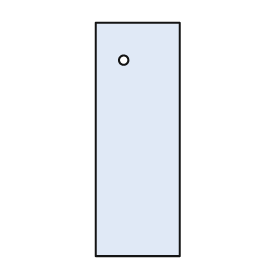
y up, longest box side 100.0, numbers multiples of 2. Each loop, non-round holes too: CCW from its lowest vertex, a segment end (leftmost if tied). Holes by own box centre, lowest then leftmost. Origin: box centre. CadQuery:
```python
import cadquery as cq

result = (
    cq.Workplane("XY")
    .moveTo(-18.0, -50.0)
    .lineTo(18.0, -50.0)
    .lineTo(18.0, 50.0)
    .lineTo(-18.0, 50.0)
    .close()
    .moveTo(-6.0, 34.0)
    .circle(2.0)
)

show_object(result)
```